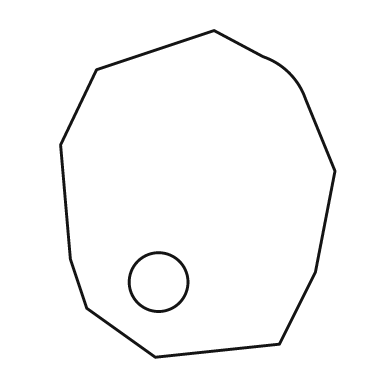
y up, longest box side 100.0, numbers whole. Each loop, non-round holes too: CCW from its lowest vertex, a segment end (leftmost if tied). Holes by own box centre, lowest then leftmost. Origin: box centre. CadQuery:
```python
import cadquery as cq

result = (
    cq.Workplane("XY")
    .moveTo(-13.0, -50.0)
    .lineTo(25.0, -46.0)
    .lineTo(36.0, -24.0)
    .lineTo(42.0, 7.0)
    .lineTo(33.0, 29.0)
    .threePointArc((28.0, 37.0), (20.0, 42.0))
    .lineTo(5.0, 50.0)
    .lineTo(-31.0, 38.0)
    .lineTo(-42.0, 15.0)
    .lineTo(-39.0, -20.0)
    .lineTo(-34.0, -35.0)
    .close()
    .moveTo(-12.0, -27.0)
    .circle(9.0)
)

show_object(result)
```